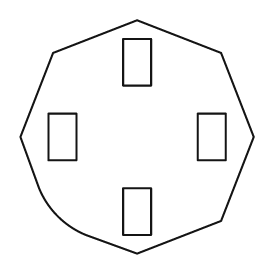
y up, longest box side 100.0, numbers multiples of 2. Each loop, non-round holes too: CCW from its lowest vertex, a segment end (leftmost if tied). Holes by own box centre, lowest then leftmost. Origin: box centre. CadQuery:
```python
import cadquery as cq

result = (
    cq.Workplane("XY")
    .moveTo(0.0, -50.0)
    .lineTo(36.0, -36.0)
    .lineTo(50.0, 0.0)
    .lineTo(36.0, 36.0)
    .lineTo(0.0, 50.0)
    .lineTo(-36.0, 36.0)
    .lineTo(-50.0, 0.0)
    .lineTo(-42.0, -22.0)
    .threePointArc((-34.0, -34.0), (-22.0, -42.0))
    .close()
    .moveTo(-6.0, -42.0)
    .lineTo(6.0, -42.0)
    .lineTo(6.0, -22.0)
    .lineTo(-6.0, -22.0)
    .close()
    .moveTo(-38.0, -10.0)
    .lineTo(-26.0, -10.0)
    .lineTo(-26.0, 10.0)
    .lineTo(-38.0, 10.0)
    .close()
    .moveTo(26.0, -10.0)
    .lineTo(38.0, -10.0)
    .lineTo(38.0, 10.0)
    .lineTo(26.0, 10.0)
    .close()
    .moveTo(-6.0, 22.0)
    .lineTo(6.0, 22.0)
    .lineTo(6.0, 42.0)
    .lineTo(-6.0, 42.0)
    .close()
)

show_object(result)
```